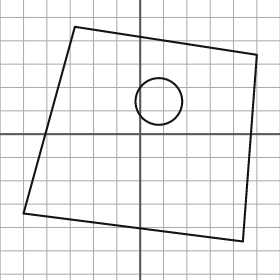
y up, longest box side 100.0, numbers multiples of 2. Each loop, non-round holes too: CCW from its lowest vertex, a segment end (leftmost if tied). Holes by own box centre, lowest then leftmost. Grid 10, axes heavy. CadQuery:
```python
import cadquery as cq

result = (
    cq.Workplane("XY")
    .moveTo(44.0, -46.0)
    .lineTo(50.0, 34.0)
    .lineTo(-28.0, 46.0)
    .lineTo(-50.0, -34.0)
    .close()
    .moveTo(8.0, 14.0)
    .circle(10.0)
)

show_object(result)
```